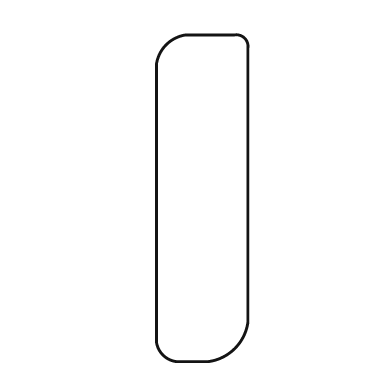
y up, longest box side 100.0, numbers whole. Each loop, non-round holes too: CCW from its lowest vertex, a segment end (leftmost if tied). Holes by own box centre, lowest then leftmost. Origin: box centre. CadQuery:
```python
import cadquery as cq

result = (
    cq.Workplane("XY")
    .moveTo(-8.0, -50.0)
    .lineTo(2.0, -50.0)
    .threePointArc((10.0, -46.0), (14.0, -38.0))
    .lineTo(14.0, 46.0)
    .threePointArc((13.0, 49.0), (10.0, 50.0))
    .lineTo(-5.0, 50.0)
    .threePointArc((-11.0, 47.0), (-14.0, 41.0))
    .lineTo(-14.0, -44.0)
    .threePointArc((-12.0, -48.0), (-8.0, -50.0))
    .close()
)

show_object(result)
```